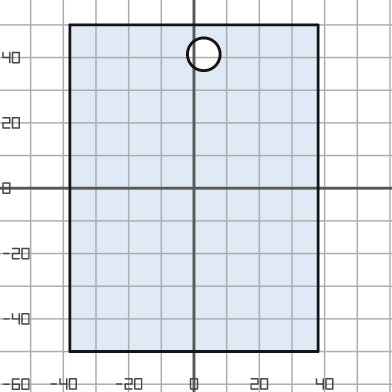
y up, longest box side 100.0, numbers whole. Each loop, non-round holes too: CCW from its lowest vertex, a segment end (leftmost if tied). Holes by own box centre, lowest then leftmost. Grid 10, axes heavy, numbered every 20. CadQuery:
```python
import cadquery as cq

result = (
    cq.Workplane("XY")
    .moveTo(-38.0, -50.0)
    .lineTo(38.0, -50.0)
    .lineTo(38.0, 50.0)
    .lineTo(-38.0, 50.0)
    .close()
    .moveTo(3.0, 41.0)
    .circle(5.0)
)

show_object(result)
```